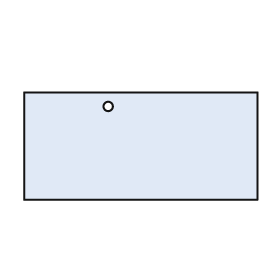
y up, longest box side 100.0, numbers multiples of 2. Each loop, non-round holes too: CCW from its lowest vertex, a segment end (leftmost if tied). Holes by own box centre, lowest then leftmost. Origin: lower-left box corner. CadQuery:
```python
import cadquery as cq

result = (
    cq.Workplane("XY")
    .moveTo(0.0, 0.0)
    .lineTo(100.0, 0.0)
    .lineTo(100.0, 46.0)
    .lineTo(0.0, 46.0)
    .close()
    .moveTo(36.0, 40.0)
    .circle(2.0)
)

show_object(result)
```